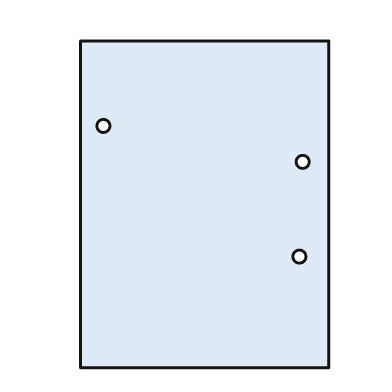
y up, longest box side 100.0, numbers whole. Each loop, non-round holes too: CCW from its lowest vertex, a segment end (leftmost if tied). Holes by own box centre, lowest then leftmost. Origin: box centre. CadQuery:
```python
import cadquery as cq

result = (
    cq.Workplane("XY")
    .moveTo(-38.0, -50.0)
    .lineTo(38.0, -50.0)
    .lineTo(38.0, 50.0)
    .lineTo(-38.0, 50.0)
    .close()
    .moveTo(29.0, -16.0)
    .circle(2.0)
    .moveTo(30.0, 13.0)
    .circle(2.0)
    .moveTo(-31.0, 24.0)
    .circle(2.0)
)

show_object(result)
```